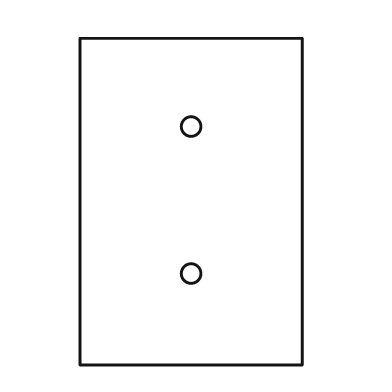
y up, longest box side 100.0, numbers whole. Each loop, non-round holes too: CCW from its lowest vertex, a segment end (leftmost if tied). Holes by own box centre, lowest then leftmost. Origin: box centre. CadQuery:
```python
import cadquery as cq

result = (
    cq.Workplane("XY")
    .moveTo(-34.0, -50.0)
    .lineTo(34.0, -50.0)
    .lineTo(34.0, 50.0)
    .lineTo(-34.0, 50.0)
    .close()
    .moveTo(0.0, -22.0)
    .circle(3.0)
    .moveTo(0.0, 23.0)
    .circle(3.0)
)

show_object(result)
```